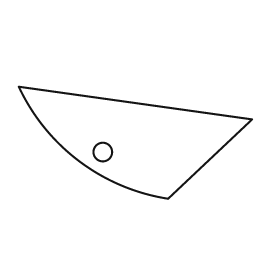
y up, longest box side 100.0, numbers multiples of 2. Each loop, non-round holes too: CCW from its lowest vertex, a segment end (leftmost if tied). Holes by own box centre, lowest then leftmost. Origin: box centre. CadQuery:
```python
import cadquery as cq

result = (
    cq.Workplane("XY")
    .moveTo(14.0, -24.0)
    .lineTo(50.0, 10.0)
    .lineTo(-50.0, 24.0)
    .threePointArc((-24.0, -8.0), (14.0, -24.0))
    .close()
    .moveTo(-14.0, -4.0)
    .circle(4.0)
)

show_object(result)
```